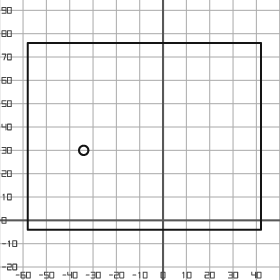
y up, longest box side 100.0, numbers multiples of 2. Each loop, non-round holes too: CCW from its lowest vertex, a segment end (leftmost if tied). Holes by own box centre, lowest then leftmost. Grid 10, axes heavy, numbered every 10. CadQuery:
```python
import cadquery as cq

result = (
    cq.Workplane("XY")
    .moveTo(-58.0, -4.0)
    .lineTo(42.0, -4.0)
    .lineTo(42.0, 76.0)
    .lineTo(-58.0, 76.0)
    .close()
    .moveTo(-34.0, 30.0)
    .circle(2.0)
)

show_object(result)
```